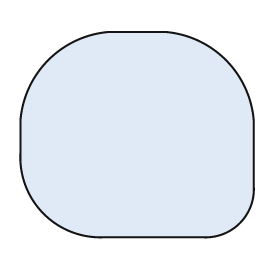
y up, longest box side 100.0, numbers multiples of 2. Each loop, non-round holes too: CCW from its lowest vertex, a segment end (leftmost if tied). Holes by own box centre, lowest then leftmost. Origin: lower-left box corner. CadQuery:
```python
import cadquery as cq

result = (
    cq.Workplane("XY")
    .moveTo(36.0, 0.0)
    .lineTo(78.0, 0.0)
    .threePointArc((94.0, 6.0), (100.0, 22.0))
    .lineTo(100.0, 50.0)
    .threePointArc((88.0, 76.0), (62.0, 88.0))
    .lineTo(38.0, 88.0)
    .threePointArc((12.0, 76.0), (0.0, 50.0))
    .lineTo(0.0, 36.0)
    .threePointArc((10.0, 10.0), (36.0, 0.0))
    .close()
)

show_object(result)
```